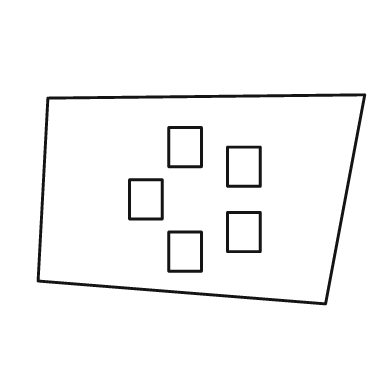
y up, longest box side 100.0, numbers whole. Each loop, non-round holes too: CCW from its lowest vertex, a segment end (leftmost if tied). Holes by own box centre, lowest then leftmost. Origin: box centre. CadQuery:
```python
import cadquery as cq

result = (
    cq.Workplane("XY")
    .moveTo(38.0, -32.0)
    .lineTo(50.0, 32.0)
    .lineTo(-47.0, 31.0)
    .lineTo(-50.0, -25.0)
    .close()
    .moveTo(-10.0, -22.0)
    .lineTo(0.0, -22.0)
    .lineTo(0.0, -10.0)
    .lineTo(-10.0, -10.0)
    .close()
    .moveTo(8.0, -16.0)
    .lineTo(18.0, -16.0)
    .lineTo(18.0, -4.0)
    .lineTo(8.0, -4.0)
    .close()
    .moveTo(-22.0, -6.0)
    .lineTo(-12.0, -6.0)
    .lineTo(-12.0, 6.0)
    .lineTo(-22.0, 6.0)
    .close()
    .moveTo(8.0, 4.0)
    .lineTo(18.0, 4.0)
    .lineTo(18.0, 16.0)
    .lineTo(8.0, 16.0)
    .close()
    .moveTo(-10.0, 10.0)
    .lineTo(0.0, 10.0)
    .lineTo(0.0, 22.0)
    .lineTo(-10.0, 22.0)
    .close()
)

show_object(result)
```